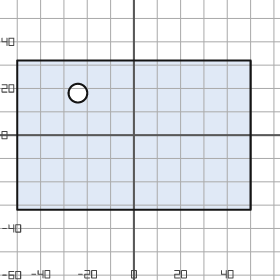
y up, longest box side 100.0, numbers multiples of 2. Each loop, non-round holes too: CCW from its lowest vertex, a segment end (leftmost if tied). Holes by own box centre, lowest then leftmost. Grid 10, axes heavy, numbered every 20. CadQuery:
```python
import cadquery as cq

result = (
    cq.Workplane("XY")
    .moveTo(-50.0, -32.0)
    .lineTo(50.0, -32.0)
    .lineTo(50.0, 32.0)
    .lineTo(-50.0, 32.0)
    .close()
    .moveTo(-24.0, 18.0)
    .circle(4.0)
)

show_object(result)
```